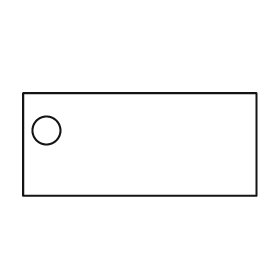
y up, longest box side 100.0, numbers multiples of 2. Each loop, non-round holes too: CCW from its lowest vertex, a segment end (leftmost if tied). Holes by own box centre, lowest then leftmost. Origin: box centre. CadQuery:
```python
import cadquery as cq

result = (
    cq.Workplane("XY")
    .moveTo(-50.0, -22.0)
    .lineTo(50.0, -22.0)
    .lineTo(50.0, 22.0)
    .lineTo(-50.0, 22.0)
    .close()
    .moveTo(-40.0, 6.0)
    .circle(6.0)
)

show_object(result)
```